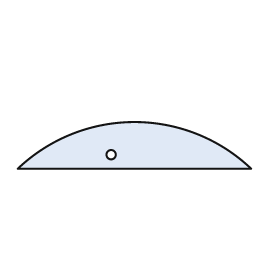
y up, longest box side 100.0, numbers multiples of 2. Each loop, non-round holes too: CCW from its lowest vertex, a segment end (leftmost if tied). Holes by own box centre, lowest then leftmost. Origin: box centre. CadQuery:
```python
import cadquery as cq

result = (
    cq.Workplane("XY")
    .moveTo(-50.0, -10.0)
    .lineTo(50.0, -10.0)
    .threePointArc((0.0, 10.0), (-50.0, -10.0))
    .close()
    .moveTo(-10.0, -4.0)
    .circle(2.0)
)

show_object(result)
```